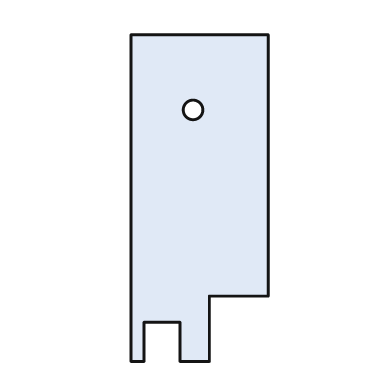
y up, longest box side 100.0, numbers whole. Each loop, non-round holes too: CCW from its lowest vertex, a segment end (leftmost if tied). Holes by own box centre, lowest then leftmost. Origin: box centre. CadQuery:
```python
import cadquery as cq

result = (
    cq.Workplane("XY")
    .moveTo(-21.0, -50.0)
    .lineTo(-17.0, -50.0)
    .lineTo(-17.0, -38.0)
    .lineTo(-6.0, -38.0)
    .lineTo(-6.0, -50.0)
    .lineTo(3.0, -50.0)
    .lineTo(3.0, -30.0)
    .lineTo(21.0, -30.0)
    .lineTo(21.0, 50.0)
    .lineTo(-21.0, 50.0)
    .close()
    .moveTo(-2.0, 27.0)
    .circle(3.0)
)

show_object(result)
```